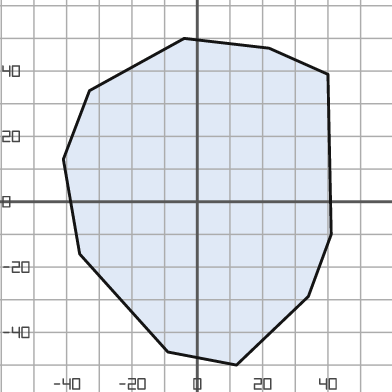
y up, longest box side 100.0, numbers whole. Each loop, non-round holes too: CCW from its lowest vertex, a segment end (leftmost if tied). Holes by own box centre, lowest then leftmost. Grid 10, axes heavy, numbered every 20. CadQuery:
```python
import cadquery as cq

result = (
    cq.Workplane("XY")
    .moveTo(12.0, -50.0)
    .lineTo(34.0, -29.0)
    .lineTo(41.0, -10.0)
    .lineTo(40.0, 39.0)
    .lineTo(22.0, 47.0)
    .lineTo(-4.0, 50.0)
    .lineTo(-33.0, 34.0)
    .lineTo(-41.0, 13.0)
    .lineTo(-36.0, -16.0)
    .lineTo(-9.0, -46.0)
    .close()
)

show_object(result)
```